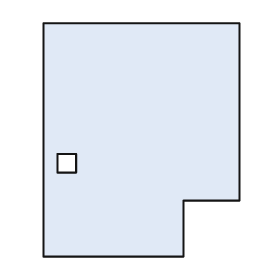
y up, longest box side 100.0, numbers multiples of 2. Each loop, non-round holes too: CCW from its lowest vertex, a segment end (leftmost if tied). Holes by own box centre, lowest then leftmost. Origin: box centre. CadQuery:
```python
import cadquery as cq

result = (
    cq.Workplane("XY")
    .moveTo(-42.0, -50.0)
    .lineTo(18.0, -50.0)
    .lineTo(18.0, -26.0)
    .lineTo(42.0, -26.0)
    .lineTo(42.0, 50.0)
    .lineTo(-42.0, 50.0)
    .close()
    .moveTo(-36.0, -14.0)
    .lineTo(-28.0, -14.0)
    .lineTo(-28.0, -6.0)
    .lineTo(-36.0, -6.0)
    .close()
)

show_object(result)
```